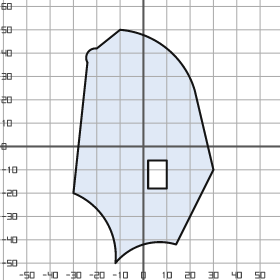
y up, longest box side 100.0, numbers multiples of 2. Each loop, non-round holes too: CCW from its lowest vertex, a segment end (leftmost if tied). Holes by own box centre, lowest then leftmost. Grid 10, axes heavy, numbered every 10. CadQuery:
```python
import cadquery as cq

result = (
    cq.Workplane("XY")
    .moveTo(-12.0, -50.0)
    .threePointArc((0.0, -42.0), (14.0, -42.0))
    .lineTo(30.0, -10.0)
    .lineTo(22.0, 24.0)
    .threePointArc((10.0, 42.0), (-10.0, 50.0))
    .lineTo(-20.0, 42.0)
    .threePointArc((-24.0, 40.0), (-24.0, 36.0))
    .lineTo(-30.0, -20.0)
    .threePointArc((-16.0, -32.0), (-12.0, -50.0))
    .close()
    .moveTo(2.0, -18.0)
    .lineTo(10.0, -18.0)
    .lineTo(10.0, -6.0)
    .lineTo(2.0, -6.0)
    .close()
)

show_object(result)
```